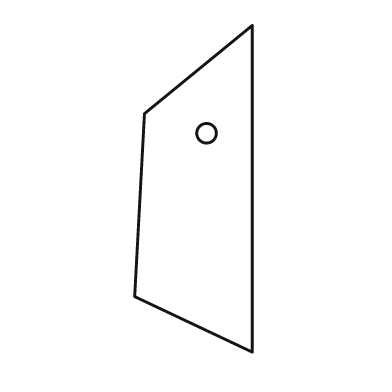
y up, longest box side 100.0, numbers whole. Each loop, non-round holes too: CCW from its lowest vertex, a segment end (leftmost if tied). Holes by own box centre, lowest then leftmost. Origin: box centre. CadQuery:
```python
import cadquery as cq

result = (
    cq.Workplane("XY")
    .moveTo(18.0, -50.0)
    .lineTo(18.0, 50.0)
    .lineTo(-15.0, 23.0)
    .lineTo(-18.0, -33.0)
    .close()
    .moveTo(4.0, 17.0)
    .circle(3.0)
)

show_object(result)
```